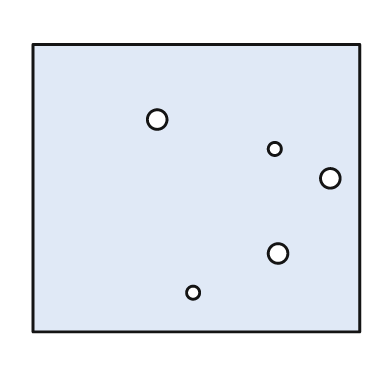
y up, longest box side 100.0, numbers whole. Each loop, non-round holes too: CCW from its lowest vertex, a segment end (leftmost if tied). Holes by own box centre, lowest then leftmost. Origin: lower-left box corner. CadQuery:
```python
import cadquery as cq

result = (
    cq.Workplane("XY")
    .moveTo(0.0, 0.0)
    .lineTo(100.0, 0.0)
    .lineTo(100.0, 88.0)
    .lineTo(0.0, 88.0)
    .close()
    .moveTo(49.0, 12.0)
    .circle(2.0)
    .moveTo(75.0, 24.0)
    .circle(3.0)
    .moveTo(91.0, 47.0)
    .circle(3.0)
    .moveTo(74.0, 56.0)
    .circle(2.0)
    .moveTo(38.0, 65.0)
    .circle(3.0)
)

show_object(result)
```